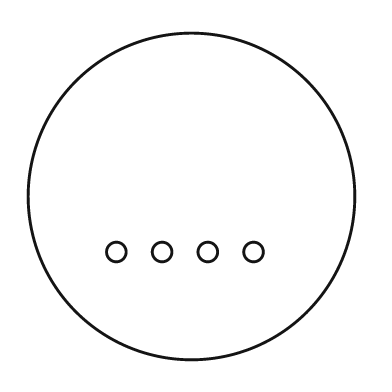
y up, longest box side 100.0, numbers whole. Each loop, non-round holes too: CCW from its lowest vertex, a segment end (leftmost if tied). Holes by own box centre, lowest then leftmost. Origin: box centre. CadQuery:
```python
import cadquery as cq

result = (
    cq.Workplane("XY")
    .moveTo(0.0, 0.0)
    .circle(50.0)
    .moveTo(-23.0, -17.0)
    .circle(3.0)
    .moveTo(-9.0, -17.0)
    .circle(3.0)
    .moveTo(5.0, -17.0)
    .circle(3.0)
    .moveTo(19.0, -17.0)
    .circle(3.0)
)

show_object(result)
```